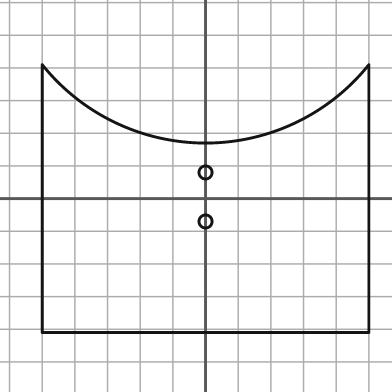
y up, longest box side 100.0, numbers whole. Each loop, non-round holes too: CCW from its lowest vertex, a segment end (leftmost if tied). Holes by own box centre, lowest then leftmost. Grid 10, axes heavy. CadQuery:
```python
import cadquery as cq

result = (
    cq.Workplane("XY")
    .moveTo(-50.0, -41.0)
    .lineTo(50.0, -41.0)
    .lineTo(50.0, 41.0)
    .threePointArc((0.0, 17.0), (-50.0, 41.0))
    .close()
    .moveTo(0.0, -7.0)
    .circle(2.0)
    .moveTo(0.0, 8.0)
    .circle(2.0)
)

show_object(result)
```